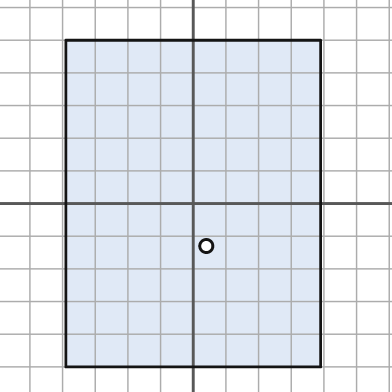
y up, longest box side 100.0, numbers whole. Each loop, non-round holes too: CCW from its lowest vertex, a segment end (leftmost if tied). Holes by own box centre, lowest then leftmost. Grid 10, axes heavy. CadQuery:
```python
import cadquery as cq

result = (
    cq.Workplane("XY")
    .moveTo(-39.0, -50.0)
    .lineTo(39.0, -50.0)
    .lineTo(39.0, 50.0)
    .lineTo(-39.0, 50.0)
    .close()
    .moveTo(4.0, -13.0)
    .circle(2.0)
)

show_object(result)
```